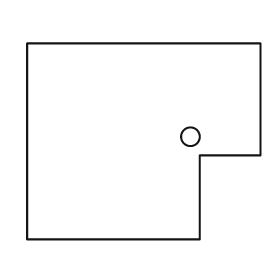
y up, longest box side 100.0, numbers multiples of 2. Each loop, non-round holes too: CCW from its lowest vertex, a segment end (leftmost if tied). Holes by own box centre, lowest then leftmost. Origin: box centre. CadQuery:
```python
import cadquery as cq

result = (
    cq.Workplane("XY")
    .moveTo(-50.0, -42.0)
    .lineTo(24.0, -42.0)
    .lineTo(24.0, -6.0)
    .lineTo(50.0, -6.0)
    .lineTo(50.0, 42.0)
    .lineTo(-50.0, 42.0)
    .close()
    .moveTo(20.0, 2.0)
    .circle(4.0)
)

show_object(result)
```